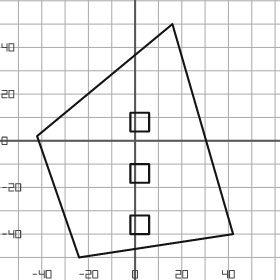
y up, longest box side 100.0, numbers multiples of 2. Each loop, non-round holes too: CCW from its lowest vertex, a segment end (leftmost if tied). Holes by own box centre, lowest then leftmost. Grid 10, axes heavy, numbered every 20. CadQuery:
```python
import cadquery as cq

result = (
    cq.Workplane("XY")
    .moveTo(-24.0, -50.0)
    .lineTo(42.0, -40.0)
    .lineTo(16.0, 50.0)
    .lineTo(-42.0, 2.0)
    .close()
    .moveTo(-2.0, -40.0)
    .lineTo(6.0, -40.0)
    .lineTo(6.0, -32.0)
    .lineTo(-2.0, -32.0)
    .close()
    .moveTo(-2.0, -18.0)
    .lineTo(6.0, -18.0)
    .lineTo(6.0, -10.0)
    .lineTo(-2.0, -10.0)
    .close()
    .moveTo(-2.0, 4.0)
    .lineTo(6.0, 4.0)
    .lineTo(6.0, 12.0)
    .lineTo(-2.0, 12.0)
    .close()
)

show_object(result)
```